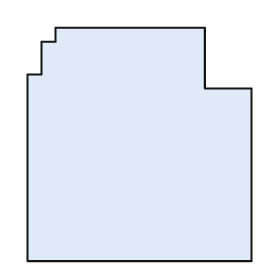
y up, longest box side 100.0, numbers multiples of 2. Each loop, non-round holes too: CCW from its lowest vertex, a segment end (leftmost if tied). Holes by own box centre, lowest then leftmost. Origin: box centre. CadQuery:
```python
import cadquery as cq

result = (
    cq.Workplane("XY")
    .moveTo(-48.0, -50.0)
    .lineTo(48.0, -50.0)
    .lineTo(48.0, 24.0)
    .lineTo(28.0, 24.0)
    .lineTo(28.0, 50.0)
    .lineTo(-36.0, 50.0)
    .lineTo(-36.0, 44.0)
    .lineTo(-42.0, 44.0)
    .lineTo(-42.0, 30.0)
    .lineTo(-48.0, 30.0)
    .close()
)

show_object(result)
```